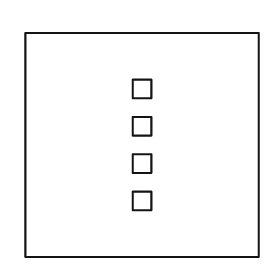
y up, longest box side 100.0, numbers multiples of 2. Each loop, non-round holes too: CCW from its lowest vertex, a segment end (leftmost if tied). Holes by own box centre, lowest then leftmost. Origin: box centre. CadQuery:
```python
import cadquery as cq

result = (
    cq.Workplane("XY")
    .moveTo(-50.0, -48.0)
    .lineTo(50.0, -48.0)
    .lineTo(50.0, 48.0)
    .lineTo(-50.0, 48.0)
    .close()
    .moveTo(-4.0, -28.0)
    .lineTo(4.0, -28.0)
    .lineTo(4.0, -20.0)
    .lineTo(-4.0, -20.0)
    .close()
    .moveTo(-4.0, -12.0)
    .lineTo(4.0, -12.0)
    .lineTo(4.0, -4.0)
    .lineTo(-4.0, -4.0)
    .close()
    .moveTo(-4.0, 4.0)
    .lineTo(4.0, 4.0)
    .lineTo(4.0, 12.0)
    .lineTo(-4.0, 12.0)
    .close()
    .moveTo(-4.0, 20.0)
    .lineTo(4.0, 20.0)
    .lineTo(4.0, 28.0)
    .lineTo(-4.0, 28.0)
    .close()
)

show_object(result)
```